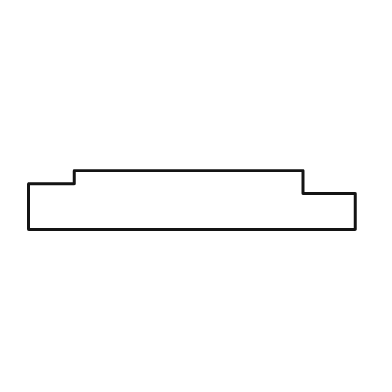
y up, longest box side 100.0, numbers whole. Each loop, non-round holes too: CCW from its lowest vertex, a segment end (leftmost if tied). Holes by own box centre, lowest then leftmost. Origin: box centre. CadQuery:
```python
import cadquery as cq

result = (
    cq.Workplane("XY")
    .moveTo(-50.0, -9.0)
    .lineTo(50.0, -9.0)
    .lineTo(50.0, 2.0)
    .lineTo(34.0, 2.0)
    .lineTo(34.0, 9.0)
    .lineTo(-36.0, 9.0)
    .lineTo(-36.0, 5.0)
    .lineTo(-50.0, 5.0)
    .close()
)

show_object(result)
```